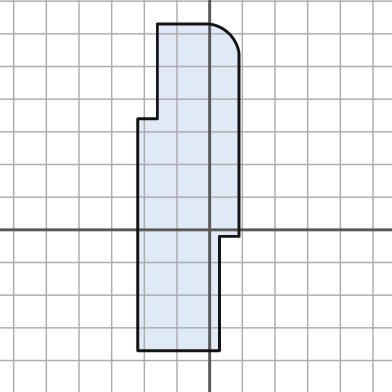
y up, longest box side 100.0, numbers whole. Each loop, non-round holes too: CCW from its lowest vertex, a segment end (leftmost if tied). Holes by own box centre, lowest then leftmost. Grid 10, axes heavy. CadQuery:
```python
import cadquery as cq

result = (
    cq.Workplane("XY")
    .moveTo(-22.0, -37.0)
    .lineTo(3.0, -37.0)
    .lineTo(3.0, -2.0)
    .lineTo(9.0, -2.0)
    .lineTo(9.0, 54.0)
    .threePointArc((6.0, 60.0), (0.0, 63.0))
    .lineTo(-16.0, 63.0)
    .lineTo(-16.0, 34.0)
    .lineTo(-22.0, 34.0)
    .close()
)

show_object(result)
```